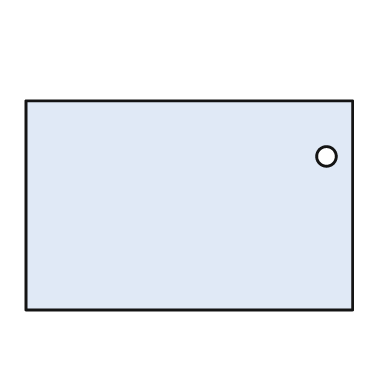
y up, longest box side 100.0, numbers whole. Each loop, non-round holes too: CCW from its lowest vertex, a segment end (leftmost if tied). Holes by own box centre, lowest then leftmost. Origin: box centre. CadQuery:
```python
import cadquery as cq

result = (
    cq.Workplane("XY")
    .moveTo(-50.0, -32.0)
    .lineTo(50.0, -32.0)
    .lineTo(50.0, 32.0)
    .lineTo(-50.0, 32.0)
    .close()
    .moveTo(42.0, 15.0)
    .circle(3.0)
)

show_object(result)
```